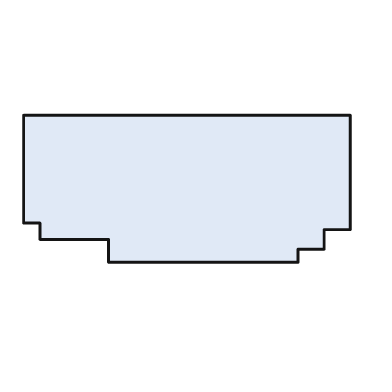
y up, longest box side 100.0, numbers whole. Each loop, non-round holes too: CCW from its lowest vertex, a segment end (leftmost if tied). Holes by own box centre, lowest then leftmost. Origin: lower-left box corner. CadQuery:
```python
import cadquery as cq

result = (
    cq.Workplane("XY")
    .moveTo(26.0, 0.0)
    .lineTo(84.0, 0.0)
    .lineTo(84.0, 4.0)
    .lineTo(92.0, 4.0)
    .lineTo(92.0, 10.0)
    .lineTo(100.0, 10.0)
    .lineTo(100.0, 45.0)
    .lineTo(0.0, 45.0)
    .lineTo(0.0, 12.0)
    .lineTo(5.0, 12.0)
    .lineTo(5.0, 7.0)
    .lineTo(26.0, 7.0)
    .close()
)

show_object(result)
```